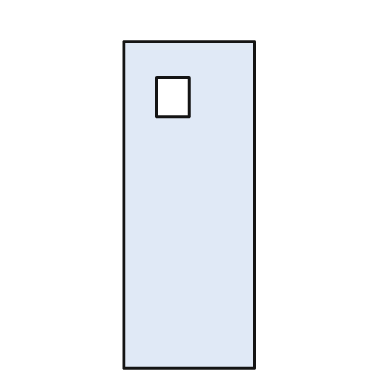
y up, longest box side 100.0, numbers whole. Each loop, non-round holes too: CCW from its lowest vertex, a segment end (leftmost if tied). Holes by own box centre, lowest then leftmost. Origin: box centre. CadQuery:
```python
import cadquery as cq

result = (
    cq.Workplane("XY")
    .moveTo(-20.0, -50.0)
    .lineTo(20.0, -50.0)
    .lineTo(20.0, 50.0)
    .lineTo(-20.0, 50.0)
    .close()
    .moveTo(-10.0, 27.0)
    .lineTo(0.0, 27.0)
    .lineTo(0.0, 39.0)
    .lineTo(-10.0, 39.0)
    .close()
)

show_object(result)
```